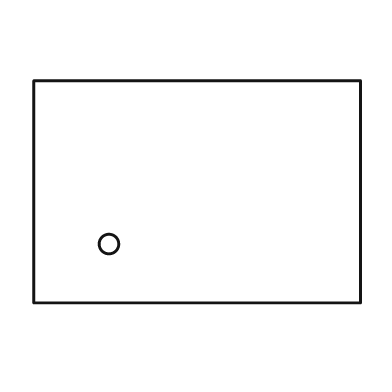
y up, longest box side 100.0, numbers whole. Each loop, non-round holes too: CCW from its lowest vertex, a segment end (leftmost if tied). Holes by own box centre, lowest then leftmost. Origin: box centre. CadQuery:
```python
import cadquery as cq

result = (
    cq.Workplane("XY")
    .moveTo(-50.0, -34.0)
    .lineTo(50.0, -34.0)
    .lineTo(50.0, 34.0)
    .lineTo(-50.0, 34.0)
    .close()
    .moveTo(-27.0, -16.0)
    .circle(3.0)
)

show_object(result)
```